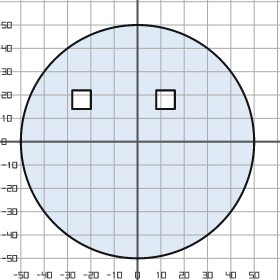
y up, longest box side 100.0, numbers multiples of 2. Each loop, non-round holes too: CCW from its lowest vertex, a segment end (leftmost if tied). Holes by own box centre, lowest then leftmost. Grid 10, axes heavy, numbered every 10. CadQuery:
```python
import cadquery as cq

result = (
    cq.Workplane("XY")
    .moveTo(0.0, 0.0)
    .circle(50.0)
    .moveTo(-28.0, 14.0)
    .lineTo(-20.0, 14.0)
    .lineTo(-20.0, 22.0)
    .lineTo(-28.0, 22.0)
    .close()
    .moveTo(8.0, 14.0)
    .lineTo(16.0, 14.0)
    .lineTo(16.0, 22.0)
    .lineTo(8.0, 22.0)
    .close()
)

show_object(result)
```